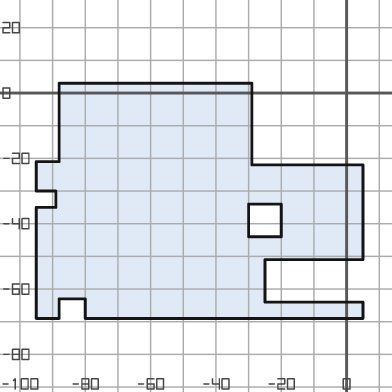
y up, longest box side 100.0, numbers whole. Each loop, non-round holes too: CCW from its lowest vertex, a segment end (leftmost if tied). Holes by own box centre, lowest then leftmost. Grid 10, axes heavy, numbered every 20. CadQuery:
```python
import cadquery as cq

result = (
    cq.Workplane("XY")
    .moveTo(-95.0, -69.0)
    .lineTo(-88.0, -69.0)
    .lineTo(-88.0, -63.0)
    .lineTo(-80.0, -63.0)
    .lineTo(-80.0, -69.0)
    .lineTo(5.0, -69.0)
    .lineTo(5.0, -64.0)
    .lineTo(-25.0, -64.0)
    .lineTo(-25.0, -51.0)
    .lineTo(5.0, -51.0)
    .lineTo(5.0, -22.0)
    .lineTo(-29.0, -22.0)
    .lineTo(-29.0, 3.0)
    .lineTo(-88.0, 3.0)
    .lineTo(-88.0, -21.0)
    .lineTo(-95.0, -21.0)
    .lineTo(-95.0, -30.0)
    .lineTo(-89.0, -30.0)
    .lineTo(-89.0, -35.0)
    .lineTo(-95.0, -35.0)
    .close()
    .moveTo(-30.0, -44.0)
    .lineTo(-20.0, -44.0)
    .lineTo(-20.0, -34.0)
    .lineTo(-30.0, -34.0)
    .close()
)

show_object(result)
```